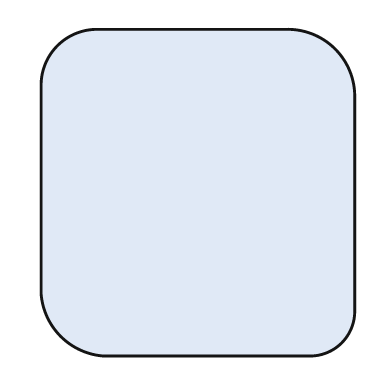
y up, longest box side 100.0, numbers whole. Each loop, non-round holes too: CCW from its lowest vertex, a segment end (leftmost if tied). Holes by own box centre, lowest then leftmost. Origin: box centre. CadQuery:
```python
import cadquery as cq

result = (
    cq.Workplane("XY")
    .moveTo(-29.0, -50.0)
    .lineTo(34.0, -50.0)
    .threePointArc((44.0, -46.0), (48.0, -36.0))
    .lineTo(48.0, 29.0)
    .threePointArc((42.0, 44.0), (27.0, 50.0))
    .lineTo(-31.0, 50.0)
    .threePointArc((-43.0, 45.0), (-48.0, 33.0))
    .lineTo(-48.0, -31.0)
    .threePointArc((-42.0, -44.0), (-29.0, -50.0))
    .close()
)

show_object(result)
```